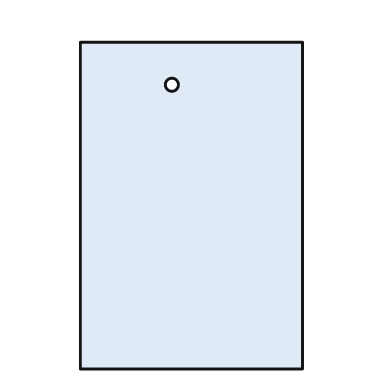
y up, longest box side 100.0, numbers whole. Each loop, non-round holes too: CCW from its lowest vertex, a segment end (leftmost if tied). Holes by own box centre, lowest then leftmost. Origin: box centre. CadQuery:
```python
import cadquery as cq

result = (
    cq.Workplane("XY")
    .moveTo(-34.0, -50.0)
    .lineTo(34.0, -50.0)
    .lineTo(34.0, 50.0)
    .lineTo(-34.0, 50.0)
    .close()
    .moveTo(-6.0, 37.0)
    .circle(2.0)
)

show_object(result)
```